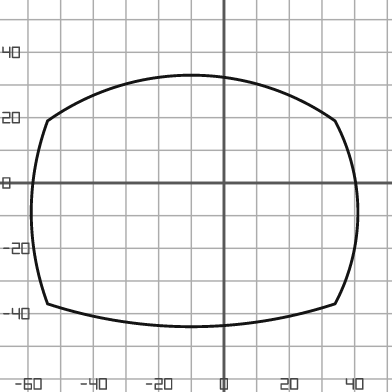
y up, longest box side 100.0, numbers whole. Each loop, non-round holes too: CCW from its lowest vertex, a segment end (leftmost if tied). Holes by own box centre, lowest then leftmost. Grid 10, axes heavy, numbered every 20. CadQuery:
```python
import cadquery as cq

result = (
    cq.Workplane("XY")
    .moveTo(-54.0, -37.0)
    .threePointArc((-10.0, -44.0), (34.0, -37.0))
    .threePointArc((41.0, -9.0), (34.0, 19.0))
    .threePointArc((-10.0, 33.0), (-54.0, 19.0))
    .threePointArc((-59.0, -9.0), (-54.0, -37.0))
    .close()
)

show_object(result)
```